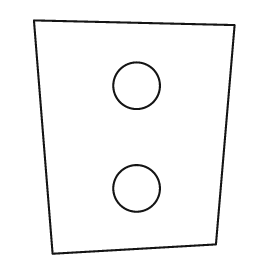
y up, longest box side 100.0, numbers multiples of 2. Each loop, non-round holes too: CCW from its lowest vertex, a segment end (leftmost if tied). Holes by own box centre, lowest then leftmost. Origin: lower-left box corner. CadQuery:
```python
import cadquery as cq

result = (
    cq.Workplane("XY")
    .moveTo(8.0, 0.0)
    .lineTo(78.0, 4.0)
    .lineTo(86.0, 98.0)
    .lineTo(0.0, 100.0)
    .close()
    .moveTo(44.0, 28.0)
    .circle(10.0)
    .moveTo(44.0, 72.0)
    .circle(10.0)
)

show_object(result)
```